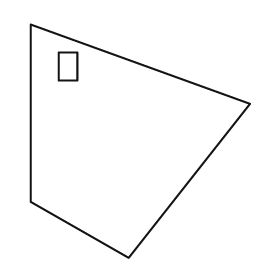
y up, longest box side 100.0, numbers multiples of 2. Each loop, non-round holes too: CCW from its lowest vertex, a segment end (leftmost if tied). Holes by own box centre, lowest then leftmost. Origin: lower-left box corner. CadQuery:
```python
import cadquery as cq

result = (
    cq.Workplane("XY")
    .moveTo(42.0, 0.0)
    .lineTo(94.0, 66.0)
    .lineTo(0.0, 100.0)
    .lineTo(0.0, 24.0)
    .close()
    .moveTo(12.0, 76.0)
    .lineTo(20.0, 76.0)
    .lineTo(20.0, 88.0)
    .lineTo(12.0, 88.0)
    .close()
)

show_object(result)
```